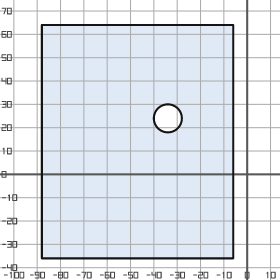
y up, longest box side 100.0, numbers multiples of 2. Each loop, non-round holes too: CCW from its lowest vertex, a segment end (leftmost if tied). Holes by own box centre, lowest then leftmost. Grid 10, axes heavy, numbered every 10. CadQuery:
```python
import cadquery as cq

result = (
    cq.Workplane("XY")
    .moveTo(-88.0, -36.0)
    .lineTo(-6.0, -36.0)
    .lineTo(-6.0, 64.0)
    .lineTo(-88.0, 64.0)
    .close()
    .moveTo(-34.0, 24.0)
    .circle(6.0)
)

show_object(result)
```